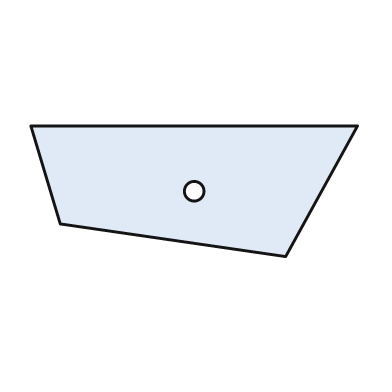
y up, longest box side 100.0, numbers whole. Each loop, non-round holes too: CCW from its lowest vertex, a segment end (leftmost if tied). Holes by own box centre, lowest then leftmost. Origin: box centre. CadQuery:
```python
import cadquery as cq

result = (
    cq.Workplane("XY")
    .moveTo(28.0, -20.0)
    .lineTo(50.0, 20.0)
    .lineTo(-50.0, 20.0)
    .lineTo(-41.0, -10.0)
    .close()
    .moveTo(0.0, 0.0)
    .circle(3.0)
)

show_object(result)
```